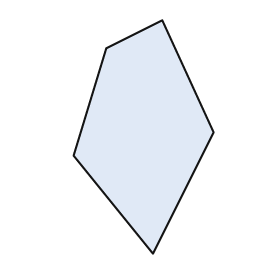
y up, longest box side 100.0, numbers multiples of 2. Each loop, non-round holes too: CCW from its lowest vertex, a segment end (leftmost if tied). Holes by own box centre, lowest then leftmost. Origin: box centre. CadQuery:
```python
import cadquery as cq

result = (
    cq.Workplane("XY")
    .moveTo(4.0, -50.0)
    .lineTo(30.0, 2.0)
    .lineTo(8.0, 50.0)
    .lineTo(-16.0, 38.0)
    .lineTo(-30.0, -8.0)
    .close()
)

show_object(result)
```